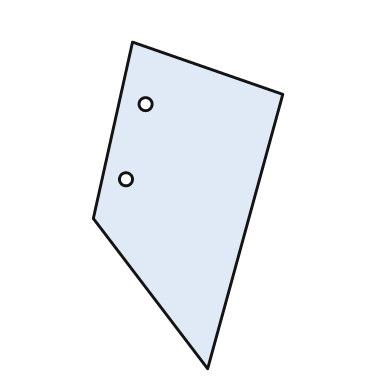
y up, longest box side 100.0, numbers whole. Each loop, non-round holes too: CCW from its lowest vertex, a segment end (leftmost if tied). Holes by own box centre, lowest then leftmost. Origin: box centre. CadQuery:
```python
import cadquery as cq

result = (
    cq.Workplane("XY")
    .moveTo(6.0, -50.0)
    .lineTo(29.0, 34.0)
    .lineTo(-17.0, 50.0)
    .lineTo(-29.0, -4.0)
    .close()
    .moveTo(-19.0, 8.0)
    .circle(2.0)
    .moveTo(-13.0, 31.0)
    .circle(2.0)
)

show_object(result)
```